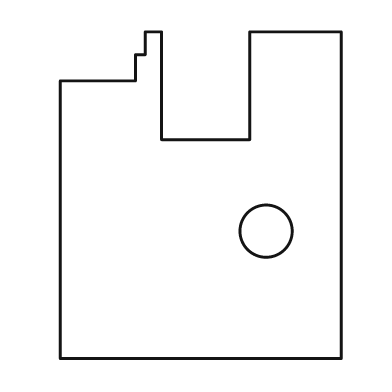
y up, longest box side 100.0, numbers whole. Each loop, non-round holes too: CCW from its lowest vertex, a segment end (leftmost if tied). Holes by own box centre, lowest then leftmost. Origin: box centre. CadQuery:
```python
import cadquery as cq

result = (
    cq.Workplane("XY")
    .moveTo(-43.0, -50.0)
    .lineTo(43.0, -50.0)
    .lineTo(43.0, 50.0)
    .lineTo(15.0, 50.0)
    .lineTo(15.0, 17.0)
    .lineTo(-12.0, 17.0)
    .lineTo(-12.0, 50.0)
    .lineTo(-17.0, 50.0)
    .lineTo(-17.0, 43.0)
    .lineTo(-20.0, 43.0)
    .lineTo(-20.0, 35.0)
    .lineTo(-43.0, 35.0)
    .close()
    .moveTo(20.0, -11.0)
    .circle(8.0)
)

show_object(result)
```